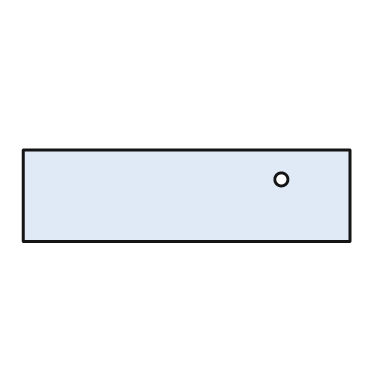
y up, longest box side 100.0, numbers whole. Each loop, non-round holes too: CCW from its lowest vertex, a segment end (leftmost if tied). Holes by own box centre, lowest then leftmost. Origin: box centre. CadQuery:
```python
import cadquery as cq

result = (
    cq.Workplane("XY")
    .moveTo(-50.0, -14.0)
    .lineTo(50.0, -14.0)
    .lineTo(50.0, 14.0)
    .lineTo(-50.0, 14.0)
    .close()
    .moveTo(29.0, 5.0)
    .circle(2.0)
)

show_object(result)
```